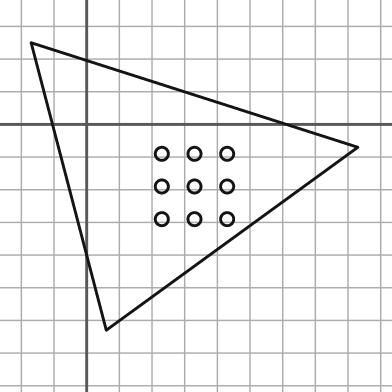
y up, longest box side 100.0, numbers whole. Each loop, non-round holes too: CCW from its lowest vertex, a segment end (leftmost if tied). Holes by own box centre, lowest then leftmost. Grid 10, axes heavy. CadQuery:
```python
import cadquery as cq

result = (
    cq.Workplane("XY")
    .moveTo(6.0, -63.0)
    .lineTo(83.0, -7.0)
    .lineTo(-17.0, 25.0)
    .close()
    .moveTo(23.0, -29.0)
    .circle(2.0)
    .moveTo(33.0, -29.0)
    .circle(2.0)
    .moveTo(43.0, -29.0)
    .circle(2.0)
    .moveTo(23.0, -19.0)
    .circle(2.0)
    .moveTo(33.0, -19.0)
    .circle(2.0)
    .moveTo(43.0, -19.0)
    .circle(2.0)
    .moveTo(23.0, -9.0)
    .circle(2.0)
    .moveTo(33.0, -9.0)
    .circle(2.0)
    .moveTo(43.0, -9.0)
    .circle(2.0)
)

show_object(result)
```